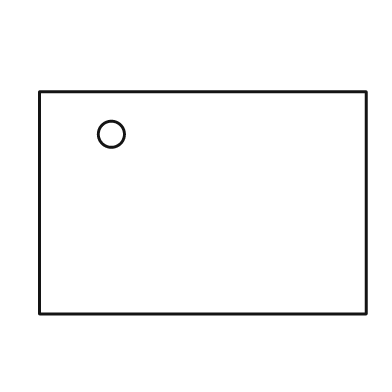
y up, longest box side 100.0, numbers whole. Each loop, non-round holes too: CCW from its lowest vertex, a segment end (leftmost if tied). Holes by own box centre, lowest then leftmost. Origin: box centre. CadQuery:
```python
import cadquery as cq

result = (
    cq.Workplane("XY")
    .moveTo(-50.0, -34.0)
    .lineTo(50.0, -34.0)
    .lineTo(50.0, 34.0)
    .lineTo(-50.0, 34.0)
    .close()
    .moveTo(-28.0, 21.0)
    .circle(4.0)
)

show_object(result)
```